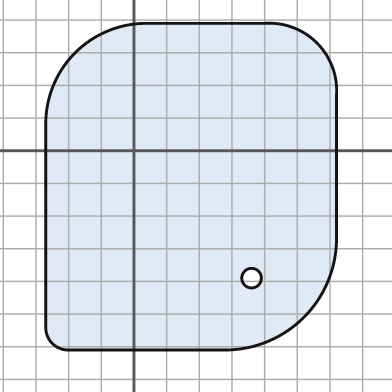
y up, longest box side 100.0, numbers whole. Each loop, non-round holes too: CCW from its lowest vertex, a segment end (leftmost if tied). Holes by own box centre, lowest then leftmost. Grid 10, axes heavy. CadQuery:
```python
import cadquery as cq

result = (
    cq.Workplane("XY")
    .moveTo(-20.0, -61.0)
    .lineTo(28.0, -61.0)
    .threePointArc((52.0, -51.0), (62.0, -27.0))
    .lineTo(62.0, 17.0)
    .threePointArc((56.0, 33.0), (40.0, 39.0))
    .lineTo(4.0, 39.0)
    .threePointArc((-18.0, 30.0), (-27.0, 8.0))
    .lineTo(-27.0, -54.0)
    .threePointArc((-25.0, -59.0), (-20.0, -61.0))
    .close()
    .moveTo(36.0, -39.0)
    .circle(3.0)
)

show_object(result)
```